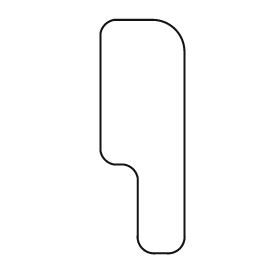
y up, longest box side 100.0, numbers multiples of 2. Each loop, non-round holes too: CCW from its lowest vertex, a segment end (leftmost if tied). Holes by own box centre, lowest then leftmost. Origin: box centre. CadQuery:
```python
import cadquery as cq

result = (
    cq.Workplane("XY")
    .moveTo(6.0, -50.0)
    .lineTo(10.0, -50.0)
    .threePointArc((16.0, -48.0), (18.0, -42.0))
    .lineTo(18.0, 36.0)
    .threePointArc((14.0, 46.0), (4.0, 50.0))
    .lineTo(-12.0, 50.0)
    .threePointArc((-16.0, 48.0), (-18.0, 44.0))
    .lineTo(-18.0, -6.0)
    .threePointArc((-16.0, -10.0), (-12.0, -12.0))
    .lineTo(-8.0, -12.0)
    .threePointArc((-4.0, -14.0), (-2.0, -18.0))
    .lineTo(-2.0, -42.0)
    .threePointArc((0.0, -48.0), (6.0, -50.0))
    .close()
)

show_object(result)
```